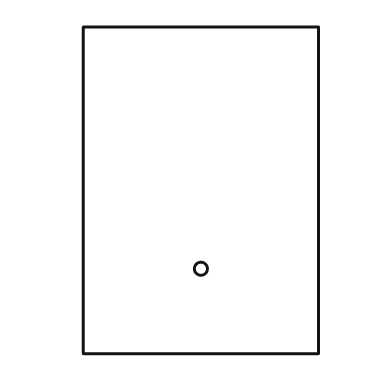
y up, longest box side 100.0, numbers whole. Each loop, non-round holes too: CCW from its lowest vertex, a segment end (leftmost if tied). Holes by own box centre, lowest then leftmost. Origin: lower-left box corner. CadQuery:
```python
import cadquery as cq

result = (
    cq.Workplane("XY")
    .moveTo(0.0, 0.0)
    .lineTo(72.0, 0.0)
    .lineTo(72.0, 100.0)
    .lineTo(0.0, 100.0)
    .close()
    .moveTo(36.0, 26.0)
    .circle(2.0)
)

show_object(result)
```